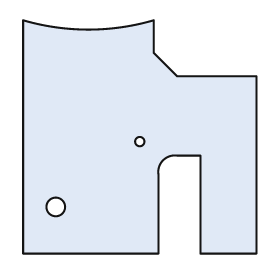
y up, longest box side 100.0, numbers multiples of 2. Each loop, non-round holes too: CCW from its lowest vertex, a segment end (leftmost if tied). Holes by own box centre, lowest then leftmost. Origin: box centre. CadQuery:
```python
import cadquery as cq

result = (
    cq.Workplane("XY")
    .moveTo(-50.0, -50.0)
    .lineTo(8.0, -50.0)
    .lineTo(8.0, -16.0)
    .threePointArc((10.0, -10.0), (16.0, -8.0))
    .lineTo(26.0, -8.0)
    .lineTo(26.0, -50.0)
    .lineTo(50.0, -50.0)
    .lineTo(50.0, 26.0)
    .lineTo(16.0, 26.0)
    .lineTo(6.0, 36.0)
    .lineTo(6.0, 50.0)
    .threePointArc((-22.0, 46.0), (-50.0, 50.0))
    .close()
    .moveTo(-36.0, -30.0)
    .circle(4.0)
    .moveTo(0.0, -2.0)
    .circle(2.0)
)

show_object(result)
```